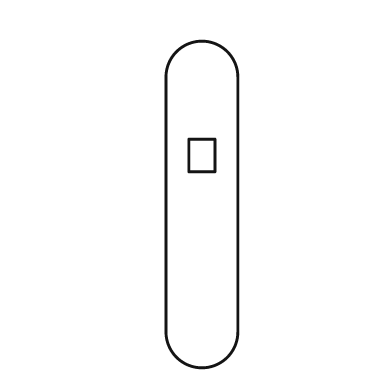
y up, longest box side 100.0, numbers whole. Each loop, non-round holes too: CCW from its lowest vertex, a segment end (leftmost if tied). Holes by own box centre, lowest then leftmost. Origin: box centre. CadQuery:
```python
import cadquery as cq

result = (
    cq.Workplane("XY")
    .moveTo(-11.0, -39.0)
    .threePointArc((0.0, -50.0), (11.0, -39.0))
    .lineTo(11.0, 39.0)
    .threePointArc((0.0, 50.0), (-11.0, 39.0))
    .close()
    .moveTo(-4.0, 10.0)
    .lineTo(4.0, 10.0)
    .lineTo(4.0, 20.0)
    .lineTo(-4.0, 20.0)
    .close()
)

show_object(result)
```